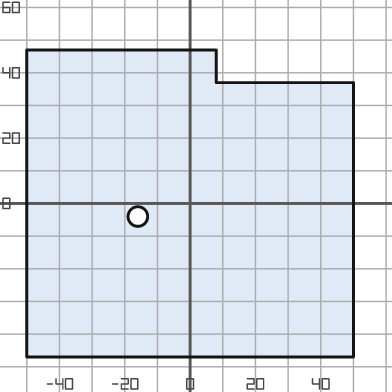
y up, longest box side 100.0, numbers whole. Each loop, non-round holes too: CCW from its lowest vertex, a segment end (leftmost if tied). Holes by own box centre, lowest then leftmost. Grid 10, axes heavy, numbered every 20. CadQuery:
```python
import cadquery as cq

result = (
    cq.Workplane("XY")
    .moveTo(-50.0, -47.0)
    .lineTo(50.0, -47.0)
    .lineTo(50.0, 37.0)
    .lineTo(8.0, 37.0)
    .lineTo(8.0, 47.0)
    .lineTo(-50.0, 47.0)
    .close()
    .moveTo(-16.0, -4.0)
    .circle(3.0)
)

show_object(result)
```